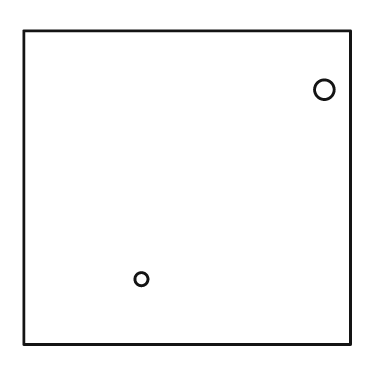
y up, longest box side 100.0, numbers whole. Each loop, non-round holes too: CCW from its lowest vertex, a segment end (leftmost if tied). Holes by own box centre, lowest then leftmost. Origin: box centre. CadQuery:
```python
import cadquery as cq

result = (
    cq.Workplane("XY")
    .moveTo(-50.0, -48.0)
    .lineTo(50.0, -48.0)
    .lineTo(50.0, 48.0)
    .lineTo(-50.0, 48.0)
    .close()
    .moveTo(-14.0, -28.0)
    .circle(2.0)
    .moveTo(42.0, 30.0)
    .circle(3.0)
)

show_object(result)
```